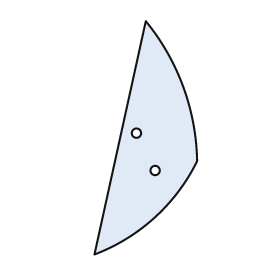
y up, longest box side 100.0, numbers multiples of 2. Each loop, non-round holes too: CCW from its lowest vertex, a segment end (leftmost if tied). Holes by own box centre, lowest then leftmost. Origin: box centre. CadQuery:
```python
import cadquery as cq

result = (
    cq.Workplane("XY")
    .moveTo(-22.0, -50.0)
    .threePointArc((4.0, -34.0), (22.0, -10.0))
    .threePointArc((16.0, 22.0), (0.0, 50.0))
    .close()
    .moveTo(4.0, -14.0)
    .circle(2.0)
    .moveTo(-4.0, 2.0)
    .circle(2.0)
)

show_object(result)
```